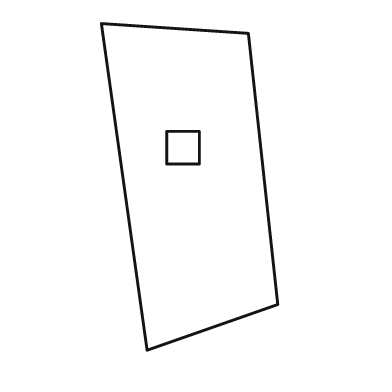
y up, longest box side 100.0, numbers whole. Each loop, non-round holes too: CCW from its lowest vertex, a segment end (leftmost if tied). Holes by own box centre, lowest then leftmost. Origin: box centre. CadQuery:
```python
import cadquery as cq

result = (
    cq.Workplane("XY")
    .moveTo(-13.0, -50.0)
    .lineTo(27.0, -36.0)
    .lineTo(18.0, 47.0)
    .lineTo(-27.0, 50.0)
    .close()
    .moveTo(-7.0, 7.0)
    .lineTo(3.0, 7.0)
    .lineTo(3.0, 17.0)
    .lineTo(-7.0, 17.0)
    .close()
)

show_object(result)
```